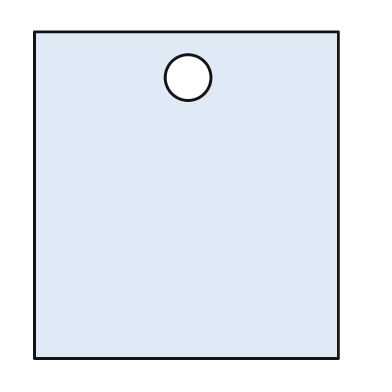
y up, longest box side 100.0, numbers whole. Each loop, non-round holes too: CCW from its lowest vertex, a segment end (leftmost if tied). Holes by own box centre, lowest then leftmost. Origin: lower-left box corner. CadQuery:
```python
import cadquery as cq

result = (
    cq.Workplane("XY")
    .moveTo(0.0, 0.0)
    .lineTo(93.0, 0.0)
    .lineTo(93.0, 100.0)
    .lineTo(0.0, 100.0)
    .close()
    .moveTo(47.0, 86.0)
    .circle(7.0)
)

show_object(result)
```